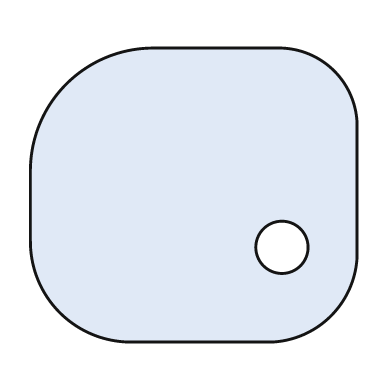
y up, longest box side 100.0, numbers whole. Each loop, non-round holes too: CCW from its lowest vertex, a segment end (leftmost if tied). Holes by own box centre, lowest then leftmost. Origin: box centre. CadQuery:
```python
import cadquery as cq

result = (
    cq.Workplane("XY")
    .moveTo(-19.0, -45.0)
    .lineTo(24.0, -45.0)
    .threePointArc((42.0, -37.0), (50.0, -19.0))
    .lineTo(50.0, 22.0)
    .threePointArc((43.0, 38.0), (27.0, 45.0))
    .lineTo(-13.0, 45.0)
    .threePointArc((-39.0, 34.0), (-50.0, 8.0))
    .lineTo(-50.0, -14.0)
    .threePointArc((-41.0, -36.0), (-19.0, -45.0))
    .close()
    .moveTo(27.0, -16.0)
    .circle(8.0)
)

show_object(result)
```